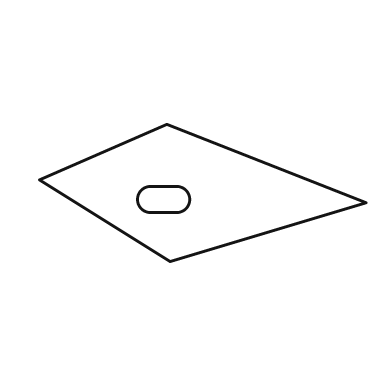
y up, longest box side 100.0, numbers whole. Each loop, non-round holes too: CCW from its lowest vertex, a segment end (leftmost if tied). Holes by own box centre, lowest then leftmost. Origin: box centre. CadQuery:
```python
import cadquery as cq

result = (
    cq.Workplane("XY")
    .moveTo(-10.0, -21.0)
    .lineTo(50.0, -3.0)
    .lineTo(-11.0, 21.0)
    .lineTo(-50.0, 4.0)
    .close()
    .moveTo(-16.0, -6.0)
    .lineTo(-8.0, -6.0)
    .threePointArc((-4.0, -2.0), (-8.0, 2.0))
    .lineTo(-16.0, 2.0)
    .threePointArc((-20.0, -2.0), (-16.0, -6.0))
    .close()
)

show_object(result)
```